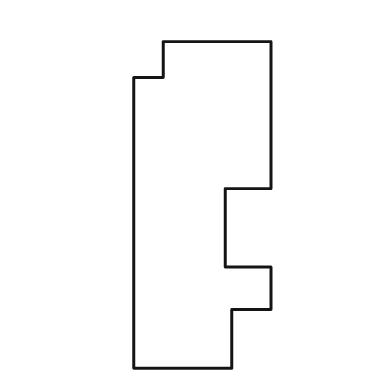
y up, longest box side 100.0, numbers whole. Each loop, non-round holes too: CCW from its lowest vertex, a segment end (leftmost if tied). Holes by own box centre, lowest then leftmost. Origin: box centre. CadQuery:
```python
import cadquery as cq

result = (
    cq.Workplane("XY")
    .moveTo(-21.0, -50.0)
    .lineTo(9.0, -50.0)
    .lineTo(9.0, -32.0)
    .lineTo(21.0, -32.0)
    .lineTo(21.0, -19.0)
    .lineTo(7.0, -19.0)
    .lineTo(7.0, 5.0)
    .lineTo(21.0, 5.0)
    .lineTo(21.0, 50.0)
    .lineTo(-12.0, 50.0)
    .lineTo(-12.0, 39.0)
    .lineTo(-21.0, 39.0)
    .close()
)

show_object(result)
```